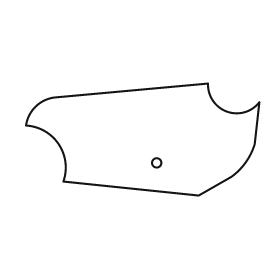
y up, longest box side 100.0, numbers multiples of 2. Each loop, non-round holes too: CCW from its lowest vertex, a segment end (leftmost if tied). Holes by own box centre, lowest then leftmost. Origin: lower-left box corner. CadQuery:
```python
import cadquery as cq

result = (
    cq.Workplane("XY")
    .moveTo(74.0, 0.0)
    .lineTo(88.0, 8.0)
    .threePointArc((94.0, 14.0), (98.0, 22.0))
    .lineTo(100.0, 40.0)
    .threePointArc((86.0, 36.0), (78.0, 48.0))
    .lineTo(12.0, 42.0)
    .threePointArc((4.0, 38.0), (0.0, 30.0))
    .threePointArc((14.0, 22.0), (16.0, 6.0))
    .close()
    .moveTo(56.0, 14.0)
    .circle(2.0)
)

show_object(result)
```